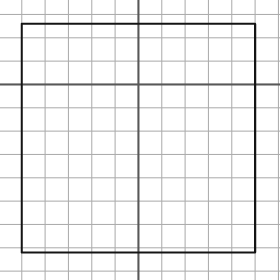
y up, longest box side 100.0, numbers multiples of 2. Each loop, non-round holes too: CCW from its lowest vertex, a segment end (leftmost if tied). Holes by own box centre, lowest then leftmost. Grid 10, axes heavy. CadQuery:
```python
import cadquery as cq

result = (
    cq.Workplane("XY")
    .moveTo(-50.0, -72.0)
    .lineTo(50.0, -72.0)
    .lineTo(50.0, 26.0)
    .lineTo(-50.0, 26.0)
    .close()
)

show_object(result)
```